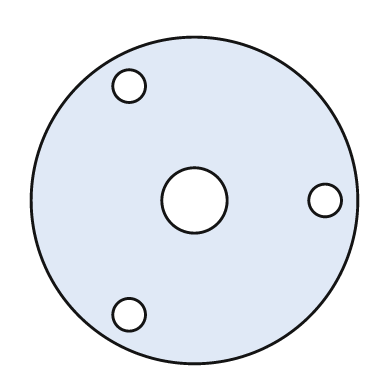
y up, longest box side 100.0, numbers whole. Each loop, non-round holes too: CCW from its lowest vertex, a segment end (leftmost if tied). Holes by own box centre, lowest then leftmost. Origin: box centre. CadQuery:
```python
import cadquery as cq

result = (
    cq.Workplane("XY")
    .moveTo(0.0, 0.0)
    .circle(50.0)
    .moveTo(-20.0, -35.0)
    .circle(5.0)
    .moveTo(0.0, 0.0)
    .circle(10.0)
    .moveTo(40.0, 0.0)
    .circle(5.0)
    .moveTo(-20.0, 35.0)
    .circle(5.0)
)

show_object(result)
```